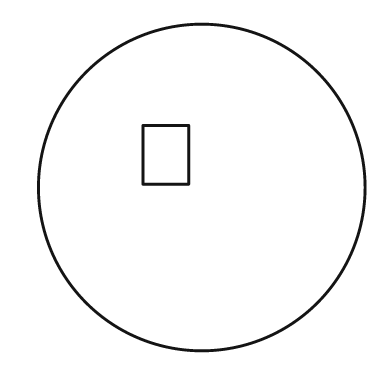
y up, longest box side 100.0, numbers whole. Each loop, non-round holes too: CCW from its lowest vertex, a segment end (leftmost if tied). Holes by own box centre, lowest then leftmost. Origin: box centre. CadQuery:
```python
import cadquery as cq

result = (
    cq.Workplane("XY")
    .moveTo(0.0, 0.0)
    .circle(50.0)
    .moveTo(-18.0, 1.0)
    .lineTo(-4.0, 1.0)
    .lineTo(-4.0, 19.0)
    .lineTo(-18.0, 19.0)
    .close()
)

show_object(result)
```